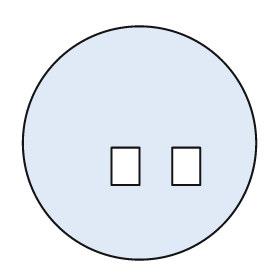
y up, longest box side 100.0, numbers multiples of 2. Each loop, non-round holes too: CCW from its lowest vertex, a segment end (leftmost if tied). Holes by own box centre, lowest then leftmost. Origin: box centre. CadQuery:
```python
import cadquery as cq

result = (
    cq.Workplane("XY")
    .moveTo(0.0, 0.0)
    .circle(50.0)
    .moveTo(-12.0, -18.0)
    .lineTo(0.0, -18.0)
    .lineTo(0.0, -2.0)
    .lineTo(-12.0, -2.0)
    .close()
    .moveTo(14.0, -18.0)
    .lineTo(26.0, -18.0)
    .lineTo(26.0, -2.0)
    .lineTo(14.0, -2.0)
    .close()
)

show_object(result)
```